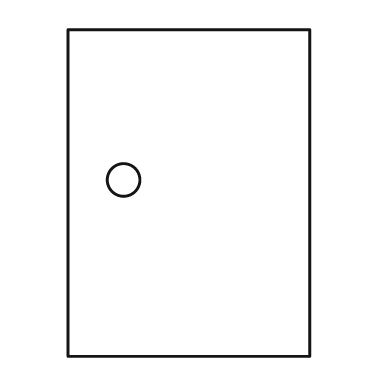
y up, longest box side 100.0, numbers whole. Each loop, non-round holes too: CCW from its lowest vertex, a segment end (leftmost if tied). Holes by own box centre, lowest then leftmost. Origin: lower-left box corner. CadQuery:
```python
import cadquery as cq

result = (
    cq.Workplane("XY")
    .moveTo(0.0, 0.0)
    .lineTo(74.0, 0.0)
    .lineTo(74.0, 100.0)
    .lineTo(0.0, 100.0)
    .close()
    .moveTo(17.0, 54.0)
    .circle(5.0)
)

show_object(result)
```